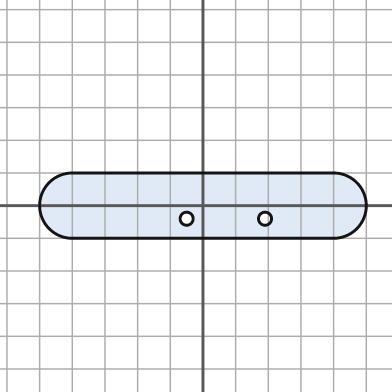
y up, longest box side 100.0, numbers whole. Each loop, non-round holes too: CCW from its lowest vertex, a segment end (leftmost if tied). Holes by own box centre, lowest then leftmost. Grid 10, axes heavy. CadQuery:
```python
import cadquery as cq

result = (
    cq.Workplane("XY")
    .moveTo(-40.0, -10.0)
    .lineTo(40.0, -10.0)
    .threePointArc((50.0, 0.0), (40.0, 10.0))
    .lineTo(-40.0, 10.0)
    .threePointArc((-50.0, 0.0), (-40.0, -10.0))
    .close()
    .moveTo(-5.0, -4.0)
    .circle(2.0)
    .moveTo(19.0, -4.0)
    .circle(2.0)
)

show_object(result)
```